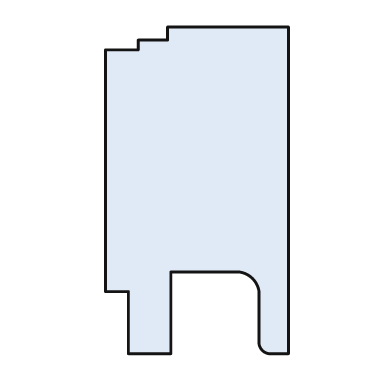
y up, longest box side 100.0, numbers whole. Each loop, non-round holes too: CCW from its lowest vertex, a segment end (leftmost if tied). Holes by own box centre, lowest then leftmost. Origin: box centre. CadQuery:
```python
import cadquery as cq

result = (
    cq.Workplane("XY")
    .moveTo(-21.0, -50.0)
    .lineTo(-8.0, -50.0)
    .lineTo(-8.0, -25.0)
    .lineTo(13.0, -25.0)
    .threePointArc((17.0, -27.0), (19.0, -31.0))
    .lineTo(19.0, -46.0)
    .threePointArc((20.0, -49.0), (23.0, -50.0))
    .lineTo(28.0, -50.0)
    .lineTo(28.0, 50.0)
    .lineTo(-9.0, 50.0)
    .lineTo(-9.0, 46.0)
    .lineTo(-18.0, 46.0)
    .lineTo(-18.0, 43.0)
    .lineTo(-28.0, 43.0)
    .lineTo(-28.0, -31.0)
    .lineTo(-21.0, -31.0)
    .close()
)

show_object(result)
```